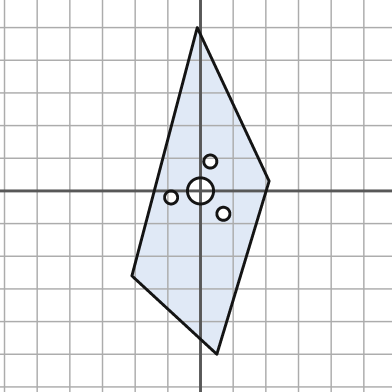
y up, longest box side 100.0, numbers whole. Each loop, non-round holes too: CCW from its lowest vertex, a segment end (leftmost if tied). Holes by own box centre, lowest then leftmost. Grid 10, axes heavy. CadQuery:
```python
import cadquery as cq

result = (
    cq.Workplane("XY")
    .moveTo(5.0, -50.0)
    .lineTo(21.0, 3.0)
    .lineTo(-1.0, 50.0)
    .lineTo(-21.0, -26.0)
    .close()
    .moveTo(7.0, -7.0)
    .circle(2.0)
    .moveTo(-9.0, -2.0)
    .circle(2.0)
    .moveTo(0.0, 0.0)
    .circle(4.0)
    .moveTo(3.0, 9.0)
    .circle(2.0)
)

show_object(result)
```